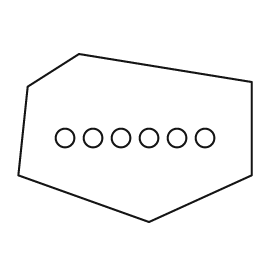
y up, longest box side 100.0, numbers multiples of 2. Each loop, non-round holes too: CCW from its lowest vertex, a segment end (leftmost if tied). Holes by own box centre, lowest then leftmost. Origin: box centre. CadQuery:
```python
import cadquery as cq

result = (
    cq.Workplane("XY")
    .moveTo(6.0, -36.0)
    .lineTo(50.0, -16.0)
    .lineTo(50.0, 24.0)
    .lineTo(-24.0, 36.0)
    .lineTo(-46.0, 22.0)
    .lineTo(-50.0, -16.0)
    .close()
    .moveTo(-30.0, 0.0)
    .circle(4.0)
    .moveTo(-18.0, 0.0)
    .circle(4.0)
    .moveTo(-6.0, 0.0)
    .circle(4.0)
    .moveTo(6.0, 0.0)
    .circle(4.0)
    .moveTo(18.0, 0.0)
    .circle(4.0)
    .moveTo(30.0, 0.0)
    .circle(4.0)
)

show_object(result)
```